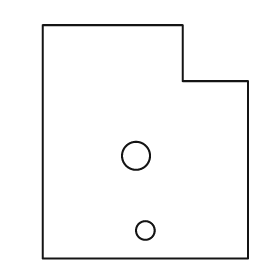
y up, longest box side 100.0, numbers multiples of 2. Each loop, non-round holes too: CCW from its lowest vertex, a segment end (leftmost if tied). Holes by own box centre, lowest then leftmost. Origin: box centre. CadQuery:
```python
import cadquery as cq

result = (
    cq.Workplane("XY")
    .moveTo(-44.0, -50.0)
    .lineTo(44.0, -50.0)
    .lineTo(44.0, 26.0)
    .lineTo(16.0, 26.0)
    .lineTo(16.0, 50.0)
    .lineTo(-44.0, 50.0)
    .close()
    .moveTo(0.0, -38.0)
    .circle(4.0)
    .moveTo(-4.0, -6.0)
    .circle(6.0)
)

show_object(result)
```